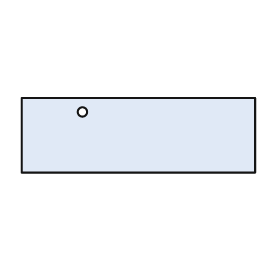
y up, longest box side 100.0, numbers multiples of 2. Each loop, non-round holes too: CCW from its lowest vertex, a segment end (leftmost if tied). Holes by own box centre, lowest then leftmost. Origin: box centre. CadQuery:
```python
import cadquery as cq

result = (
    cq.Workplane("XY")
    .moveTo(-50.0, -16.0)
    .lineTo(50.0, -16.0)
    .lineTo(50.0, 16.0)
    .lineTo(-50.0, 16.0)
    .close()
    .moveTo(-24.0, 10.0)
    .circle(2.0)
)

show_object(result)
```